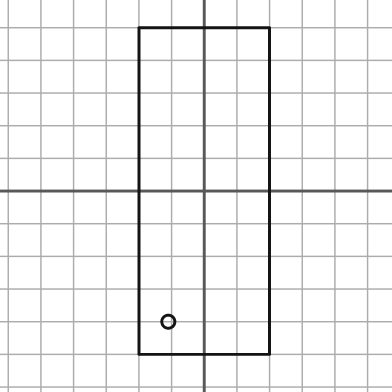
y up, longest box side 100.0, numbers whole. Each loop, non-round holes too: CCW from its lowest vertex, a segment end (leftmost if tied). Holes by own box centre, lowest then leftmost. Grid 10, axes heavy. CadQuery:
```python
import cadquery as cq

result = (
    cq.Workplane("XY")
    .moveTo(-20.0, -50.0)
    .lineTo(20.0, -50.0)
    .lineTo(20.0, 50.0)
    .lineTo(-20.0, 50.0)
    .close()
    .moveTo(-11.0, -40.0)
    .circle(2.0)
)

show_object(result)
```